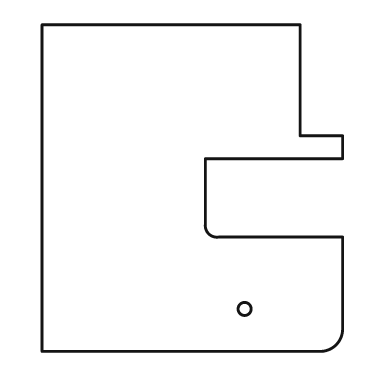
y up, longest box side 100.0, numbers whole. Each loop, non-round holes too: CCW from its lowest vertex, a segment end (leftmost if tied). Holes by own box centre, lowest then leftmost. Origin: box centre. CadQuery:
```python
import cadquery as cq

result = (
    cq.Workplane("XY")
    .moveTo(-46.0, -50.0)
    .lineTo(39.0, -50.0)
    .threePointArc((44.0, -48.0), (46.0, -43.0))
    .lineTo(46.0, -15.0)
    .lineTo(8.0, -15.0)
    .threePointArc((5.0, -14.0), (4.0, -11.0))
    .lineTo(4.0, 9.0)
    .lineTo(46.0, 9.0)
    .lineTo(46.0, 16.0)
    .lineTo(33.0, 16.0)
    .lineTo(33.0, 50.0)
    .lineTo(-46.0, 50.0)
    .close()
    .moveTo(16.0, -37.0)
    .circle(2.0)
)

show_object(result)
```